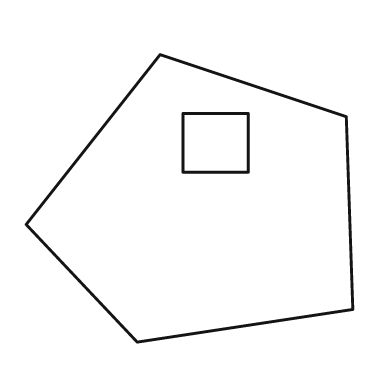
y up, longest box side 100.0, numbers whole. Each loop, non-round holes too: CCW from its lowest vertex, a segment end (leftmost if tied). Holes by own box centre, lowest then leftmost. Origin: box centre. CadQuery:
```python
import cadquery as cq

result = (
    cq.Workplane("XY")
    .moveTo(-16.0, -44.0)
    .lineTo(50.0, -34.0)
    .lineTo(48.0, 25.0)
    .lineTo(-9.0, 44.0)
    .lineTo(-50.0, -8.0)
    .close()
    .moveTo(-2.0, 8.0)
    .lineTo(18.0, 8.0)
    .lineTo(18.0, 26.0)
    .lineTo(-2.0, 26.0)
    .close()
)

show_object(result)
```